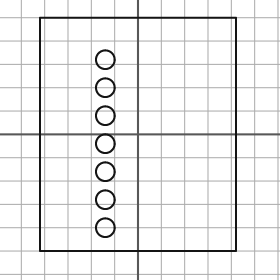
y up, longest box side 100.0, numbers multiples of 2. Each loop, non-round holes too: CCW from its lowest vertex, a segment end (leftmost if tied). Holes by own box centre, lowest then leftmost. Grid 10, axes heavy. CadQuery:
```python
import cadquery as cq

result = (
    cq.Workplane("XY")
    .moveTo(-42.0, -50.0)
    .lineTo(42.0, -50.0)
    .lineTo(42.0, 50.0)
    .lineTo(-42.0, 50.0)
    .close()
    .moveTo(-14.0, -40.0)
    .circle(4.0)
    .moveTo(-14.0, -28.0)
    .circle(4.0)
    .moveTo(-14.0, -16.0)
    .circle(4.0)
    .moveTo(-14.0, -4.0)
    .circle(4.0)
    .moveTo(-14.0, 8.0)
    .circle(4.0)
    .moveTo(-14.0, 20.0)
    .circle(4.0)
    .moveTo(-14.0, 32.0)
    .circle(4.0)
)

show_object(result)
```